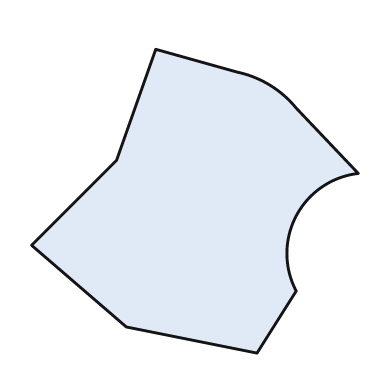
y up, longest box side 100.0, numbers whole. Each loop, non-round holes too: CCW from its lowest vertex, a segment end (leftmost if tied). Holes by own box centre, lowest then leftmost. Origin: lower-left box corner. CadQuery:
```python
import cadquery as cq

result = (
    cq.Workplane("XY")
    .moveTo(69.0, 0.0)
    .lineTo(81.0, 19.0)
    .threePointArc((81.0, 42.0), (100.0, 55.0))
    .lineTo(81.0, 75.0)
    .threePointArc((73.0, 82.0), (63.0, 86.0))
    .lineTo(38.0, 93.0)
    .lineTo(26.0, 59.0)
    .lineTo(0.0, 33.0)
    .lineTo(29.0, 8.0)
    .close()
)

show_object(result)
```